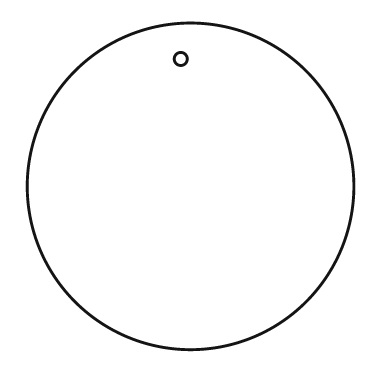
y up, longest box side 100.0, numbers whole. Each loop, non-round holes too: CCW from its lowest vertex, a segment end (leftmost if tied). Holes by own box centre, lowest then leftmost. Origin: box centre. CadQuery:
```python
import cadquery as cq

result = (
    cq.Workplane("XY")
    .moveTo(0.0, 0.0)
    .circle(50.0)
    .moveTo(-3.0, 39.0)
    .circle(2.0)
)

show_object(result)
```